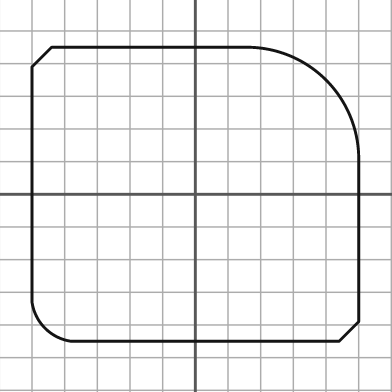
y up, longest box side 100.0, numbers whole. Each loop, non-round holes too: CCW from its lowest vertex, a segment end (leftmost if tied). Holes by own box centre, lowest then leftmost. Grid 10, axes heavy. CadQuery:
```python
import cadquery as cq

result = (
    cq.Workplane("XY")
    .moveTo(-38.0, -45.0)
    .lineTo(44.0, -45.0)
    .lineTo(50.0, -39.0)
    .lineTo(50.0, 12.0)
    .threePointArc((40.0, 35.0), (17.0, 45.0))
    .lineTo(-44.0, 45.0)
    .lineTo(-50.0, 39.0)
    .lineTo(-50.0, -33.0)
    .threePointArc((-46.0, -41.0), (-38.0, -45.0))
    .close()
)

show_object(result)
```